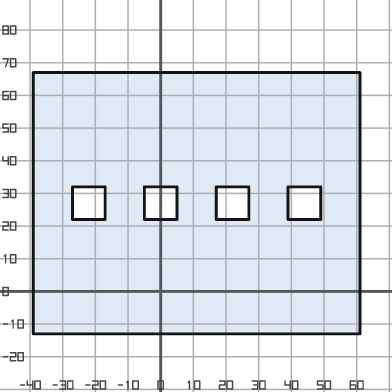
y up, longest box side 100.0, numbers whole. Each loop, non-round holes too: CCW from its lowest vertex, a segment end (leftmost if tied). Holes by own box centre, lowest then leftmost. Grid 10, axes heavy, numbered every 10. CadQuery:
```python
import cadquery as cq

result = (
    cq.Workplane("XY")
    .moveTo(-39.0, -13.0)
    .lineTo(61.0, -13.0)
    .lineTo(61.0, 67.0)
    .lineTo(-39.0, 67.0)
    .close()
    .moveTo(-27.0, 22.0)
    .lineTo(-17.0, 22.0)
    .lineTo(-17.0, 32.0)
    .lineTo(-27.0, 32.0)
    .close()
    .moveTo(-5.0, 22.0)
    .lineTo(5.0, 22.0)
    .lineTo(5.0, 32.0)
    .lineTo(-5.0, 32.0)
    .close()
    .moveTo(17.0, 22.0)
    .lineTo(27.0, 22.0)
    .lineTo(27.0, 32.0)
    .lineTo(17.0, 32.0)
    .close()
    .moveTo(39.0, 22.0)
    .lineTo(49.0, 22.0)
    .lineTo(49.0, 32.0)
    .lineTo(39.0, 32.0)
    .close()
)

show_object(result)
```